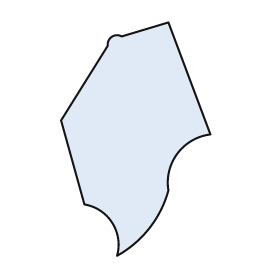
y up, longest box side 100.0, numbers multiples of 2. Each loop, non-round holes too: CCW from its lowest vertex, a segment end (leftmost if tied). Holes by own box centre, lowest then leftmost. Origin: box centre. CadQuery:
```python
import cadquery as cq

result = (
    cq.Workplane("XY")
    .moveTo(-8.0, -50.0)
    .threePointArc((6.0, -38.0), (14.0, -22.0))
    .threePointArc((18.0, -6.0), (32.0, 2.0))
    .lineTo(14.0, 50.0)
    .lineTo(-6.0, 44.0)
    .threePointArc((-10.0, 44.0), (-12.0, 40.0))
    .lineTo(-32.0, 8.0)
    .lineTo(-22.0, -28.0)
    .threePointArc((-10.0, -36.0), (-8.0, -50.0))
    .close()
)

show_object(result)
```